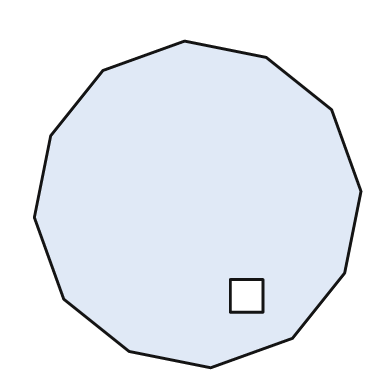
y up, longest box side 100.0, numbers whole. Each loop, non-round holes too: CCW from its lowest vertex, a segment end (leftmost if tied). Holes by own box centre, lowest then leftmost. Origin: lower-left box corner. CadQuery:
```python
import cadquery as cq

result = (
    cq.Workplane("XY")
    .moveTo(54.0, 0.0)
    .lineTo(79.0, 9.0)
    .lineTo(95.0, 29.0)
    .lineTo(100.0, 54.0)
    .lineTo(91.0, 79.0)
    .lineTo(71.0, 95.0)
    .lineTo(46.0, 100.0)
    .lineTo(21.0, 91.0)
    .lineTo(5.0, 71.0)
    .lineTo(0.0, 46.0)
    .lineTo(9.0, 21.0)
    .lineTo(29.0, 5.0)
    .close()
    .moveTo(60.0, 17.0)
    .lineTo(70.0, 17.0)
    .lineTo(70.0, 27.0)
    .lineTo(60.0, 27.0)
    .close()
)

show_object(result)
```